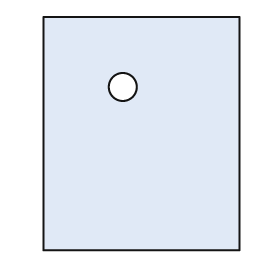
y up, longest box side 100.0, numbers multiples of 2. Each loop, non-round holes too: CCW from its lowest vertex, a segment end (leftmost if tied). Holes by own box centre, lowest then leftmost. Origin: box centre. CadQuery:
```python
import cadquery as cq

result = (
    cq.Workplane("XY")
    .moveTo(-42.0, -50.0)
    .lineTo(42.0, -50.0)
    .lineTo(42.0, 50.0)
    .lineTo(-42.0, 50.0)
    .close()
    .moveTo(-8.0, 20.0)
    .circle(6.0)
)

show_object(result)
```